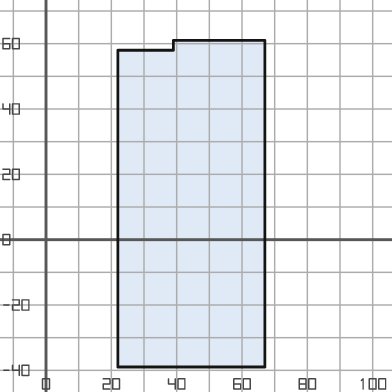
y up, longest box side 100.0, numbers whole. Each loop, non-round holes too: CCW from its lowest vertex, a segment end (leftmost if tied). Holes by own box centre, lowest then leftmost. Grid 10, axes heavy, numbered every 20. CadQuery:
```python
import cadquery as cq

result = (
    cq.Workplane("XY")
    .moveTo(22.0, -39.0)
    .lineTo(67.0, -39.0)
    .lineTo(67.0, 61.0)
    .lineTo(39.0, 61.0)
    .lineTo(39.0, 58.0)
    .lineTo(22.0, 58.0)
    .close()
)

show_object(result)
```